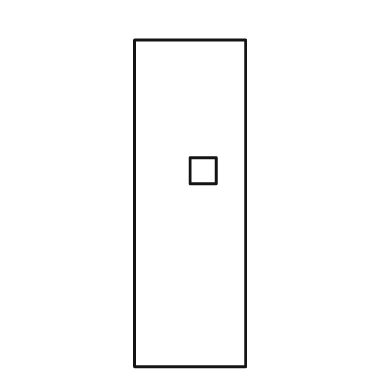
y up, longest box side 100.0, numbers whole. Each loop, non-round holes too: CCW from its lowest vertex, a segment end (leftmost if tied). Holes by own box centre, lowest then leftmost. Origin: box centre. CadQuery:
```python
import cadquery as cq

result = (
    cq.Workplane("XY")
    .moveTo(-17.0, -50.0)
    .lineTo(17.0, -50.0)
    .lineTo(17.0, 50.0)
    .lineTo(-17.0, 50.0)
    .close()
    .moveTo(0.0, 6.0)
    .lineTo(8.0, 6.0)
    .lineTo(8.0, 14.0)
    .lineTo(0.0, 14.0)
    .close()
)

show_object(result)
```